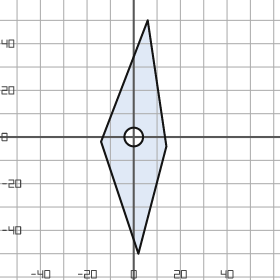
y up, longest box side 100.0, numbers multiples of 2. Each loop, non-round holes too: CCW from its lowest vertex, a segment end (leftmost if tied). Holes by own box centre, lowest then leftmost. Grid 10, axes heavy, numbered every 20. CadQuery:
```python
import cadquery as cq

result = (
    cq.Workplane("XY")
    .moveTo(2.0, -50.0)
    .lineTo(14.0, -4.0)
    .lineTo(6.0, 50.0)
    .lineTo(-14.0, -2.0)
    .close()
    .moveTo(0.0, 0.0)
    .circle(4.0)
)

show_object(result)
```